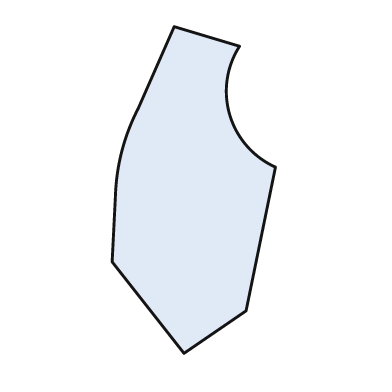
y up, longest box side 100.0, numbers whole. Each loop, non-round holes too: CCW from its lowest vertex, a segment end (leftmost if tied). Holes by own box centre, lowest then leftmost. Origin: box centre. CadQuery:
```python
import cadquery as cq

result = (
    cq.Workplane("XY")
    .moveTo(-3.0, -50.0)
    .lineTo(16.0, -37.0)
    .lineTo(25.0, 7.0)
    .threePointArc((11.0, 23.0), (14.0, 44.0))
    .lineTo(-6.0, 50.0)
    .lineTo(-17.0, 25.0)
    .threePointArc((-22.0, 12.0), (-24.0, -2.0))
    .lineTo(-25.0, -22.0)
    .close()
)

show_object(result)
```